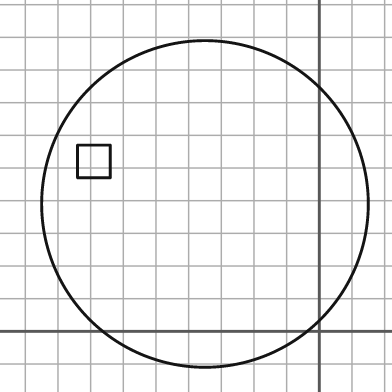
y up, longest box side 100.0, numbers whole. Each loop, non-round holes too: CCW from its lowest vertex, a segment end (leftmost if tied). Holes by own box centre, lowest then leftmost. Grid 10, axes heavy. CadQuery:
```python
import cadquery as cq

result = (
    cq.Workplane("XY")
    .moveTo(-35.0, 39.0)
    .circle(50.0)
    .moveTo(-74.0, 47.0)
    .lineTo(-64.0, 47.0)
    .lineTo(-64.0, 57.0)
    .lineTo(-74.0, 57.0)
    .close()
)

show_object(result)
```